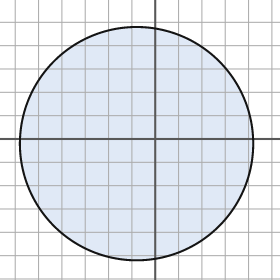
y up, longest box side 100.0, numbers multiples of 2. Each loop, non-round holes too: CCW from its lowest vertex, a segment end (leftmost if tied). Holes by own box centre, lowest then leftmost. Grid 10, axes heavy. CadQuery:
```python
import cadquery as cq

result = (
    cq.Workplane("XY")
    .moveTo(-8.0, -2.0)
    .circle(50.0)
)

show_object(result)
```